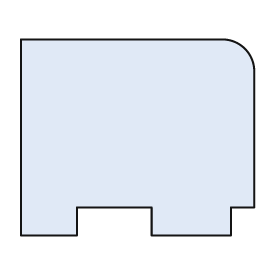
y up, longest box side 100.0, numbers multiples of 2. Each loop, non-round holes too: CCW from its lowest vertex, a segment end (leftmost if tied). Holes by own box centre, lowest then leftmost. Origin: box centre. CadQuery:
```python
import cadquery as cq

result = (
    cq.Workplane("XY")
    .moveTo(-50.0, -42.0)
    .lineTo(-26.0, -42.0)
    .lineTo(-26.0, -30.0)
    .lineTo(6.0, -30.0)
    .lineTo(6.0, -42.0)
    .lineTo(40.0, -42.0)
    .lineTo(40.0, -30.0)
    .lineTo(50.0, -30.0)
    .lineTo(50.0, 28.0)
    .threePointArc((46.0, 38.0), (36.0, 42.0))
    .lineTo(-50.0, 42.0)
    .close()
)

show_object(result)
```